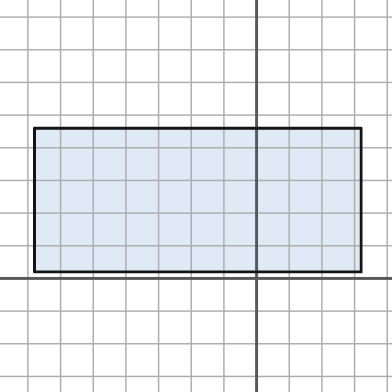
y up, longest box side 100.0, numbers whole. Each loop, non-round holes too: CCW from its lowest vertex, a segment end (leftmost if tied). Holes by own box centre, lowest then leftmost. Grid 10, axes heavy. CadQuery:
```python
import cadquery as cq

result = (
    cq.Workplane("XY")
    .moveTo(-68.0, 2.0)
    .lineTo(32.0, 2.0)
    .lineTo(32.0, 46.0)
    .lineTo(-68.0, 46.0)
    .close()
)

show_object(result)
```